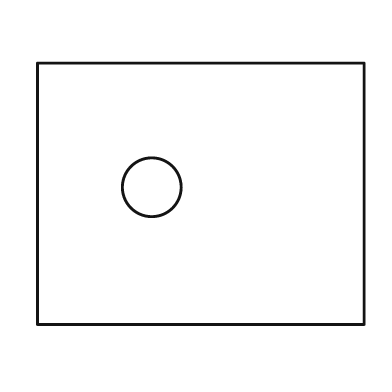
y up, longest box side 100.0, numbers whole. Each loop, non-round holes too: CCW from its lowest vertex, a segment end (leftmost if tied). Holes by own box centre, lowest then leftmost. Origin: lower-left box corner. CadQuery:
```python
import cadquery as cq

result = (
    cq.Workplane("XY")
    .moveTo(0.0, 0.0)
    .lineTo(100.0, 0.0)
    .lineTo(100.0, 80.0)
    .lineTo(0.0, 80.0)
    .close()
    .moveTo(35.0, 42.0)
    .circle(9.0)
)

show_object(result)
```